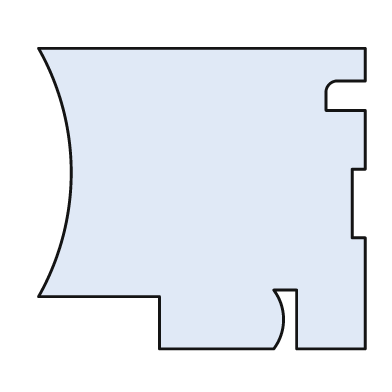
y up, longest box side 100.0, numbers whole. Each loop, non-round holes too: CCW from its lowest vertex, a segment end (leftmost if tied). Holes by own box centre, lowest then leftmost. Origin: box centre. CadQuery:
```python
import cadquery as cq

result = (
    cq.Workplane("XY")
    .moveTo(-13.0, -46.0)
    .lineTo(22.0, -46.0)
    .threePointArc((25.0, -37.0), (22.0, -28.0))
    .lineTo(29.0, -28.0)
    .lineTo(29.0, -46.0)
    .lineTo(50.0, -46.0)
    .lineTo(50.0, -12.0)
    .lineTo(46.0, -12.0)
    .lineTo(46.0, 9.0)
    .lineTo(50.0, 9.0)
    .lineTo(50.0, 27.0)
    .lineTo(38.0, 27.0)
    .lineTo(38.0, 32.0)
    .threePointArc((39.0, 35.0), (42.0, 36.0))
    .lineTo(50.0, 36.0)
    .lineTo(50.0, 46.0)
    .lineTo(-50.0, 46.0)
    .threePointArc((-40.0, 8.0), (-50.0, -30.0))
    .lineTo(-13.0, -30.0)
    .close()
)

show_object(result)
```